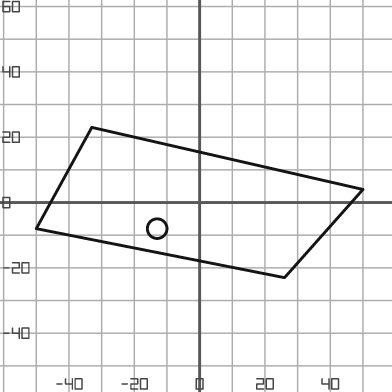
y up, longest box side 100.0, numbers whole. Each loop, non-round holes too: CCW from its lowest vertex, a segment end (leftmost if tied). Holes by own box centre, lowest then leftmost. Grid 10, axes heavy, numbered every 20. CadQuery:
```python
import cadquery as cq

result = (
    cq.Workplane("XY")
    .moveTo(26.0, -23.0)
    .lineTo(50.0, 4.0)
    .lineTo(-33.0, 23.0)
    .lineTo(-50.0, -8.0)
    .close()
    .moveTo(-13.0, -8.0)
    .circle(3.0)
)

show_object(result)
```